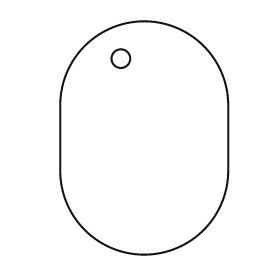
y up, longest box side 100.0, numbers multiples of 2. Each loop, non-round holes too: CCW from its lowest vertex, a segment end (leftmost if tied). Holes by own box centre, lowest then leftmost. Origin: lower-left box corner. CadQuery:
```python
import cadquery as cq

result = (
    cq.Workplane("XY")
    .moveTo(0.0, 36.0)
    .threePointArc((36.0, 0.0), (72.0, 36.0))
    .lineTo(72.0, 64.0)
    .threePointArc((36.0, 100.0), (0.0, 64.0))
    .close()
    .moveTo(26.0, 84.0)
    .circle(4.0)
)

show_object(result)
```